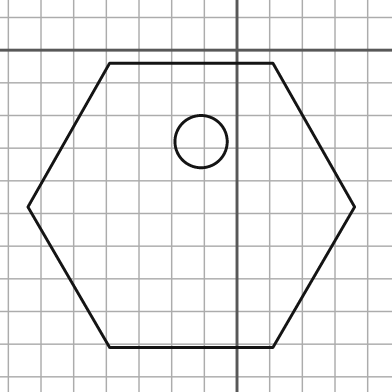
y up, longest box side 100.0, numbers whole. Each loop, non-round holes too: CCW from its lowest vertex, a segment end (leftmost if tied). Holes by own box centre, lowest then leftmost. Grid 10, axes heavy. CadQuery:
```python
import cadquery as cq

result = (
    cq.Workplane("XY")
    .moveTo(-39.0, -91.0)
    .lineTo(11.0, -91.0)
    .lineTo(36.0, -48.0)
    .lineTo(11.0, -4.0)
    .lineTo(-39.0, -4.0)
    .lineTo(-64.0, -48.0)
    .close()
    .moveTo(-11.0, -28.0)
    .circle(8.0)
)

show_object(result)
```